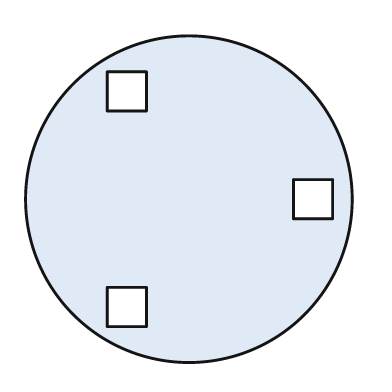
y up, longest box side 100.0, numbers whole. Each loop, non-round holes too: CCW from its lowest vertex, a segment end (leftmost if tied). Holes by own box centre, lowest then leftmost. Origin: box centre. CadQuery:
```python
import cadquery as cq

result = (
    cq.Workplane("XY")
    .moveTo(0.0, 0.0)
    .circle(50.0)
    .moveTo(-25.0, -39.0)
    .lineTo(-13.0, -39.0)
    .lineTo(-13.0, -27.0)
    .lineTo(-25.0, -27.0)
    .close()
    .moveTo(32.0, -6.0)
    .lineTo(44.0, -6.0)
    .lineTo(44.0, 6.0)
    .lineTo(32.0, 6.0)
    .close()
    .moveTo(-25.0, 27.0)
    .lineTo(-13.0, 27.0)
    .lineTo(-13.0, 39.0)
    .lineTo(-25.0, 39.0)
    .close()
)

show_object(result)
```